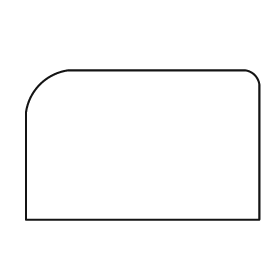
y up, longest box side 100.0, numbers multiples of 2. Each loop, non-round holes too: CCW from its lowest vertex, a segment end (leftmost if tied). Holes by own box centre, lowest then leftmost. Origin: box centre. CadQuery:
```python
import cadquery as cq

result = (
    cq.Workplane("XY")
    .moveTo(-50.0, -32.0)
    .lineTo(50.0, -32.0)
    .lineTo(50.0, 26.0)
    .threePointArc((48.0, 30.0), (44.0, 32.0))
    .lineTo(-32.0, 32.0)
    .threePointArc((-44.0, 26.0), (-50.0, 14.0))
    .close()
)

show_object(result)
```